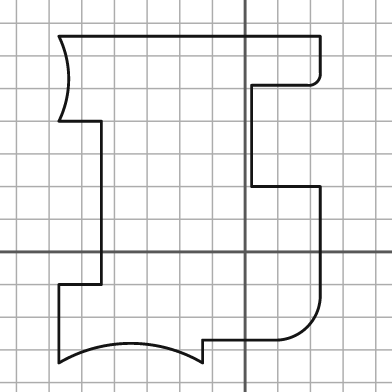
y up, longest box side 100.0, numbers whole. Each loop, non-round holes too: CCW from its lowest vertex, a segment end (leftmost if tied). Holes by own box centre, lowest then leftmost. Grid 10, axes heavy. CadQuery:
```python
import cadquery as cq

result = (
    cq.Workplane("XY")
    .moveTo(-57.0, -34.0)
    .threePointArc((-35.0, -28.0), (-13.0, -34.0))
    .lineTo(-13.0, -27.0)
    .lineTo(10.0, -27.0)
    .threePointArc((19.0, -23.0), (23.0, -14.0))
    .lineTo(23.0, 20.0)
    .lineTo(2.0, 20.0)
    .lineTo(2.0, 51.0)
    .lineTo(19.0, 51.0)
    .threePointArc((22.0, 52.0), (23.0, 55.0))
    .lineTo(23.0, 66.0)
    .lineTo(-57.0, 66.0)
    .threePointArc((-54.0, 53.0), (-57.0, 40.0))
    .lineTo(-44.0, 40.0)
    .lineTo(-44.0, -10.0)
    .lineTo(-57.0, -10.0)
    .close()
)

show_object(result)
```